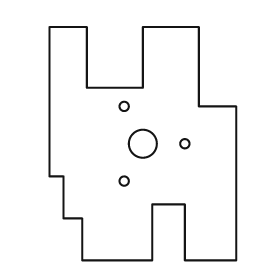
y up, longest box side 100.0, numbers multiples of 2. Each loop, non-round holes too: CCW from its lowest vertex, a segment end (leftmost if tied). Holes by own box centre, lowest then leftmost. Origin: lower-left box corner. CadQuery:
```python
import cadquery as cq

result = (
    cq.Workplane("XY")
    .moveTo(14.0, 0.0)
    .lineTo(44.0, 0.0)
    .lineTo(44.0, 24.0)
    .lineTo(58.0, 24.0)
    .lineTo(58.0, 0.0)
    .lineTo(80.0, 0.0)
    .lineTo(80.0, 66.0)
    .lineTo(64.0, 66.0)
    .lineTo(64.0, 100.0)
    .lineTo(40.0, 100.0)
    .lineTo(40.0, 74.0)
    .lineTo(16.0, 74.0)
    .lineTo(16.0, 100.0)
    .lineTo(0.0, 100.0)
    .lineTo(0.0, 36.0)
    .lineTo(6.0, 36.0)
    .lineTo(6.0, 18.0)
    .lineTo(14.0, 18.0)
    .close()
    .moveTo(32.0, 34.0)
    .circle(2.0)
    .moveTo(40.0, 50.0)
    .circle(6.0)
    .moveTo(58.0, 50.0)
    .circle(2.0)
    .moveTo(32.0, 66.0)
    .circle(2.0)
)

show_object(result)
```